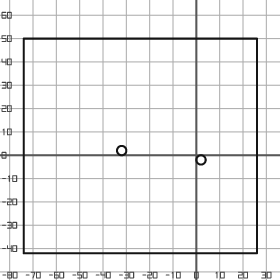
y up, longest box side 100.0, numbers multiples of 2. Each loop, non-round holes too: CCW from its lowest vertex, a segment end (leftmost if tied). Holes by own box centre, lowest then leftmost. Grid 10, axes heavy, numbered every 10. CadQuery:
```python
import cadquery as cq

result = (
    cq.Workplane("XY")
    .moveTo(-74.0, -42.0)
    .lineTo(26.0, -42.0)
    .lineTo(26.0, 50.0)
    .lineTo(-74.0, 50.0)
    .close()
    .moveTo(2.0, -2.0)
    .circle(2.0)
    .moveTo(-32.0, 2.0)
    .circle(2.0)
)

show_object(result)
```